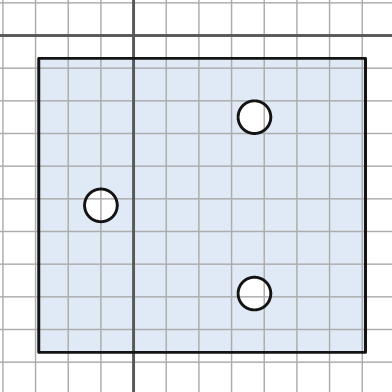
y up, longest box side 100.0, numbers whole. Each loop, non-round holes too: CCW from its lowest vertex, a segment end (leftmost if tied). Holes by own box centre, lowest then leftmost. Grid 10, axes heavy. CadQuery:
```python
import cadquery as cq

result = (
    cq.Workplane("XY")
    .moveTo(-29.0, -97.0)
    .lineTo(71.0, -97.0)
    .lineTo(71.0, -7.0)
    .lineTo(-29.0, -7.0)
    .close()
    .moveTo(37.0, -79.0)
    .circle(5.0)
    .moveTo(-10.0, -52.0)
    .circle(5.0)
    .moveTo(37.0, -25.0)
    .circle(5.0)
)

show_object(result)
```